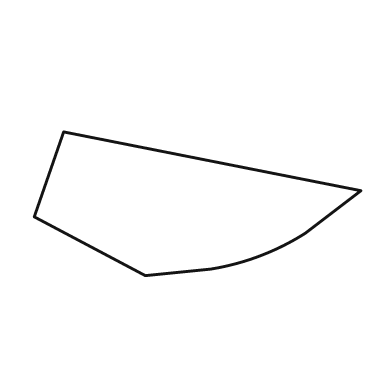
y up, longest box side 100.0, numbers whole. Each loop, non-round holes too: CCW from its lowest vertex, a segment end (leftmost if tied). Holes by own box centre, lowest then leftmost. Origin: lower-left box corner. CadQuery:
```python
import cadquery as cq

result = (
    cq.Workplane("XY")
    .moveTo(34.0, 0.0)
    .lineTo(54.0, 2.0)
    .threePointArc((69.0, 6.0), (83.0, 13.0))
    .lineTo(100.0, 26.0)
    .lineTo(9.0, 44.0)
    .lineTo(0.0, 18.0)
    .close()
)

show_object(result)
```